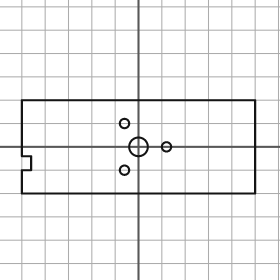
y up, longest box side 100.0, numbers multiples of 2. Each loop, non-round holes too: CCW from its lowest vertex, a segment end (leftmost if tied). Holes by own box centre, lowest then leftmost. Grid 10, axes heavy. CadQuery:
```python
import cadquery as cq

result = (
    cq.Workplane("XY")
    .moveTo(-50.0, -20.0)
    .lineTo(50.0, -20.0)
    .lineTo(50.0, 20.0)
    .lineTo(-50.0, 20.0)
    .lineTo(-50.0, -4.0)
    .lineTo(-46.0, -4.0)
    .lineTo(-46.0, -10.0)
    .lineTo(-50.0, -10.0)
    .close()
    .moveTo(-6.0, -10.0)
    .circle(2.0)
    .moveTo(0.0, 0.0)
    .circle(4.0)
    .moveTo(12.0, 0.0)
    .circle(2.0)
    .moveTo(-6.0, 10.0)
    .circle(2.0)
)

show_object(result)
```